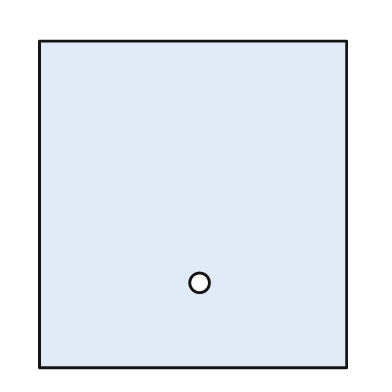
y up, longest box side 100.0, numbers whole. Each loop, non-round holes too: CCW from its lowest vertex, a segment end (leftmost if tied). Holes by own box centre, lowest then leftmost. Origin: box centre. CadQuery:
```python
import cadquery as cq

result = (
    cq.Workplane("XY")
    .moveTo(-47.0, -50.0)
    .lineTo(47.0, -50.0)
    .lineTo(47.0, 50.0)
    .lineTo(-47.0, 50.0)
    .close()
    .moveTo(2.0, -24.0)
    .circle(3.0)
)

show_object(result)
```